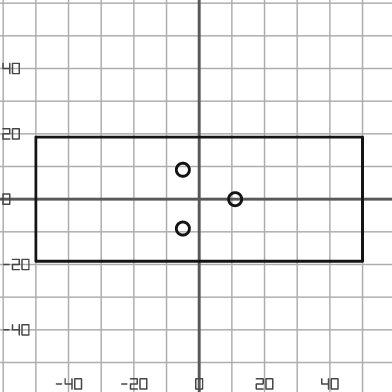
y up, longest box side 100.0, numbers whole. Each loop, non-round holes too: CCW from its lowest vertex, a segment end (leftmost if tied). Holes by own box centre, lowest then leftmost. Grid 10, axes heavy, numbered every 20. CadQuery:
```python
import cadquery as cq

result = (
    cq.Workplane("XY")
    .moveTo(-50.0, -19.0)
    .lineTo(50.0, -19.0)
    .lineTo(50.0, 19.0)
    .lineTo(-50.0, 19.0)
    .close()
    .moveTo(-5.0, -9.0)
    .circle(2.0)
    .moveTo(11.0, 0.0)
    .circle(2.0)
    .moveTo(-5.0, 9.0)
    .circle(2.0)
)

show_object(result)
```